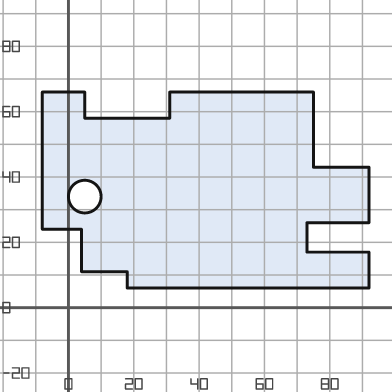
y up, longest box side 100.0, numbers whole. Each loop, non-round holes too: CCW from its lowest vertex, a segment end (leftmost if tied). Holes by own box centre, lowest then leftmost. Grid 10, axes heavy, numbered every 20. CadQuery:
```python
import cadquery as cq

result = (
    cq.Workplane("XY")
    .moveTo(18.0, 6.0)
    .lineTo(92.0, 6.0)
    .lineTo(92.0, 17.0)
    .lineTo(73.0, 17.0)
    .lineTo(73.0, 26.0)
    .lineTo(92.0, 26.0)
    .lineTo(92.0, 43.0)
    .lineTo(75.0, 43.0)
    .lineTo(75.0, 66.0)
    .lineTo(31.0, 66.0)
    .lineTo(31.0, 58.0)
    .lineTo(5.0, 58.0)
    .lineTo(5.0, 66.0)
    .lineTo(-8.0, 66.0)
    .lineTo(-8.0, 24.0)
    .lineTo(4.0, 24.0)
    .lineTo(4.0, 11.0)
    .lineTo(18.0, 11.0)
    .close()
    .moveTo(5.0, 34.0)
    .circle(5.0)
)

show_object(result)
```